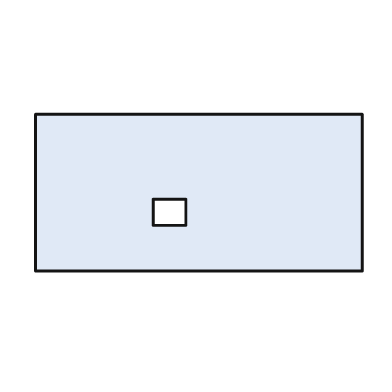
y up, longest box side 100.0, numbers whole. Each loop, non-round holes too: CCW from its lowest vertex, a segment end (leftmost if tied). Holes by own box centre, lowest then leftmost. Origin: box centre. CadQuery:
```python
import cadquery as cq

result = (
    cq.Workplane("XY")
    .moveTo(-50.0, -24.0)
    .lineTo(50.0, -24.0)
    .lineTo(50.0, 24.0)
    .lineTo(-50.0, 24.0)
    .close()
    .moveTo(-14.0, -10.0)
    .lineTo(-4.0, -10.0)
    .lineTo(-4.0, -2.0)
    .lineTo(-14.0, -2.0)
    .close()
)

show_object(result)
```